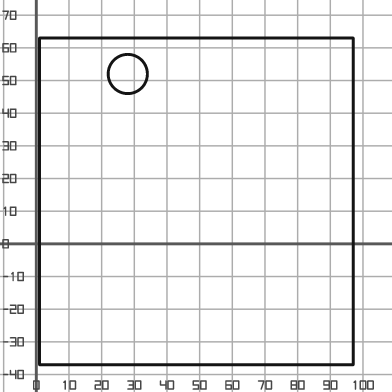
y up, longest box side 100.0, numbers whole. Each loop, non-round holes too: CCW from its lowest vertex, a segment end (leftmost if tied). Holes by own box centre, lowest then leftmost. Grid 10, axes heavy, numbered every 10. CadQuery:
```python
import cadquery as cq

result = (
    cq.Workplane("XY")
    .moveTo(1.0, -37.0)
    .lineTo(97.0, -37.0)
    .lineTo(97.0, 63.0)
    .lineTo(1.0, 63.0)
    .close()
    .moveTo(28.0, 52.0)
    .circle(6.0)
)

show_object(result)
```